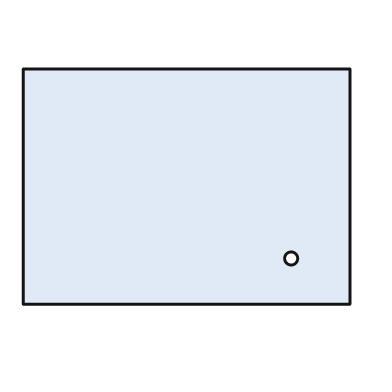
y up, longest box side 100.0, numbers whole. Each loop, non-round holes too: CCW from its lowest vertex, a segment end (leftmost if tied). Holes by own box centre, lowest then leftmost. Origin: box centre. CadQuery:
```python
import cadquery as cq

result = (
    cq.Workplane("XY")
    .moveTo(-50.0, -36.0)
    .lineTo(50.0, -36.0)
    .lineTo(50.0, 36.0)
    .lineTo(-50.0, 36.0)
    .close()
    .moveTo(32.0, -22.0)
    .circle(2.0)
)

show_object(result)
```